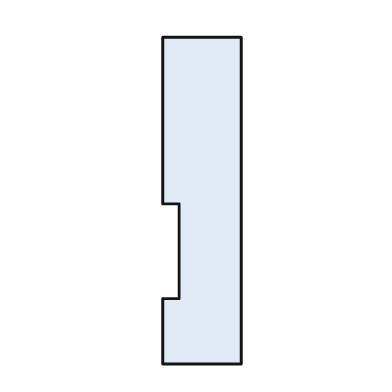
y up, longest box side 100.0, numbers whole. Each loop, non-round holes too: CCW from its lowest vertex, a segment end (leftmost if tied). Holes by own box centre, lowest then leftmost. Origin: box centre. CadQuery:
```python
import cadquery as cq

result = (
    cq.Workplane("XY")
    .moveTo(-12.0, -50.0)
    .lineTo(12.0, -50.0)
    .lineTo(12.0, 50.0)
    .lineTo(-12.0, 50.0)
    .lineTo(-12.0, -1.0)
    .lineTo(-7.0, -1.0)
    .lineTo(-7.0, -30.0)
    .lineTo(-12.0, -30.0)
    .close()
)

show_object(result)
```